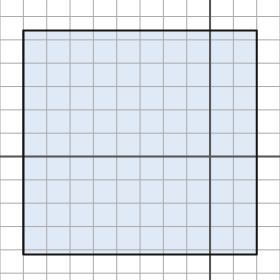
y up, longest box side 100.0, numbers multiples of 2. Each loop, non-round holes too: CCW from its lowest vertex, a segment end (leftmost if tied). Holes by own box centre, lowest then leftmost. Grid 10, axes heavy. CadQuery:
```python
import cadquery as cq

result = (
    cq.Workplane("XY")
    .moveTo(-80.0, -42.0)
    .lineTo(20.0, -42.0)
    .lineTo(20.0, 54.0)
    .lineTo(-80.0, 54.0)
    .close()
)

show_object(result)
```